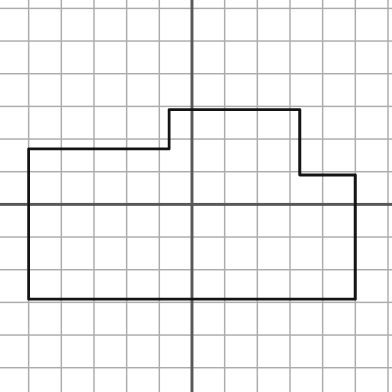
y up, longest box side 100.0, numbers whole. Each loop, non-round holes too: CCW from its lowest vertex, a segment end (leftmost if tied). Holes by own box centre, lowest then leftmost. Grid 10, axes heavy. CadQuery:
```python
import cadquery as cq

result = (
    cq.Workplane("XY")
    .moveTo(-50.0, -29.0)
    .lineTo(50.0, -29.0)
    .lineTo(50.0, 9.0)
    .lineTo(33.0, 9.0)
    .lineTo(33.0, 29.0)
    .lineTo(-7.0, 29.0)
    .lineTo(-7.0, 17.0)
    .lineTo(-50.0, 17.0)
    .close()
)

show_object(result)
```